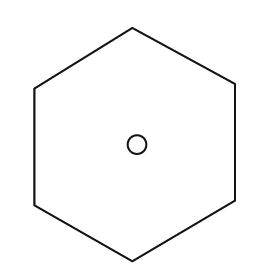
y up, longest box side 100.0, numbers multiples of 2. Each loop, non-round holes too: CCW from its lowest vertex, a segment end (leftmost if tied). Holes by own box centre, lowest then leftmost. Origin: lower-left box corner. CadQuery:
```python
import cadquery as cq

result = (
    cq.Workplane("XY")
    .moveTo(42.0, 0.0)
    .lineTo(86.0, 26.0)
    .lineTo(86.0, 76.0)
    .lineTo(42.0, 100.0)
    .lineTo(0.0, 74.0)
    .lineTo(0.0, 24.0)
    .close()
    .moveTo(44.0, 50.0)
    .circle(4.0)
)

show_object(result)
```